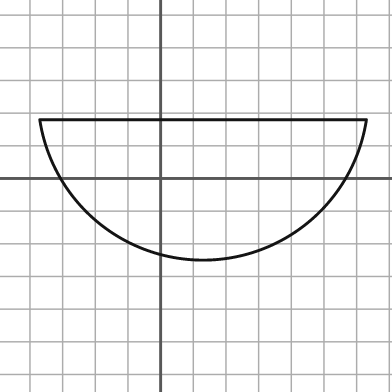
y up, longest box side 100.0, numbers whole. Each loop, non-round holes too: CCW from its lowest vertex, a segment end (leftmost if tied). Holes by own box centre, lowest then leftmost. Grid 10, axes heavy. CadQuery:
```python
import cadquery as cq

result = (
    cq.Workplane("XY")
    .moveTo(-37.0, 18.0)
    .threePointArc((13.0, -25.0), (63.0, 18.0))
    .close()
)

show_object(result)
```